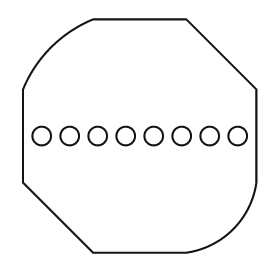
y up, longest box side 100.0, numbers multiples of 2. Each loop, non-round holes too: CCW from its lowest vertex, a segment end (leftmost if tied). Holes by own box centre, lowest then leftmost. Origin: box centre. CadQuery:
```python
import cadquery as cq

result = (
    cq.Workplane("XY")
    .moveTo(-20.0, -50.0)
    .lineTo(20.0, -50.0)
    .threePointArc((40.0, -40.0), (50.0, -20.0))
    .lineTo(50.0, 20.0)
    .lineTo(20.0, 50.0)
    .lineTo(-20.0, 50.0)
    .threePointArc((-38.0, 38.0), (-50.0, 20.0))
    .lineTo(-50.0, -20.0)
    .close()
    .moveTo(-42.0, 0.0)
    .circle(4.0)
    .moveTo(-30.0, 0.0)
    .circle(4.0)
    .moveTo(-18.0, 0.0)
    .circle(4.0)
    .moveTo(-6.0, 0.0)
    .circle(4.0)
    .moveTo(6.0, 0.0)
    .circle(4.0)
    .moveTo(18.0, 0.0)
    .circle(4.0)
    .moveTo(30.0, 0.0)
    .circle(4.0)
    .moveTo(42.0, 0.0)
    .circle(4.0)
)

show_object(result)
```